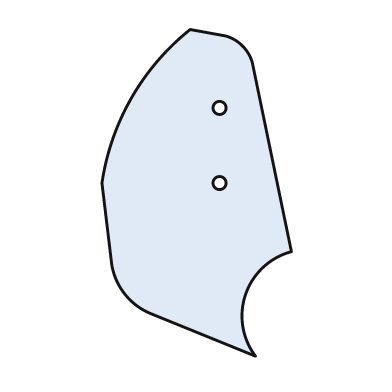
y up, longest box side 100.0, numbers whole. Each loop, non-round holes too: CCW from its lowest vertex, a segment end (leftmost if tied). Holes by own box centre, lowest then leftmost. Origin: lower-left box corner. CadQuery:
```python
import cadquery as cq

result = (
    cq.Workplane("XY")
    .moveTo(47.0, 0.0)
    .threePointArc((44.0, 19.0), (58.0, 32.0))
    .lineTo(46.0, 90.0)
    .threePointArc((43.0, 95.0), (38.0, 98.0))
    .lineTo(27.0, 100.0)
    .threePointArc((9.0, 79.0), (0.0, 53.0))
    .lineTo(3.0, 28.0)
    .threePointArc((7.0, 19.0), (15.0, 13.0))
    .close()
    .moveTo(36.0, 53.0)
    .circle(2.0)
    .moveTo(36.0, 76.0)
    .circle(2.0)
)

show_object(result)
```